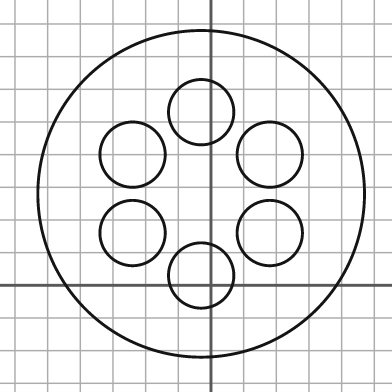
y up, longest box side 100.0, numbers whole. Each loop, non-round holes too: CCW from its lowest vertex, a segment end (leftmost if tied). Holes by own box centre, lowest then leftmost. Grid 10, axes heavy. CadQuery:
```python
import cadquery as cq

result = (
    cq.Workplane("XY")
    .moveTo(-3.0, 28.0)
    .circle(50.0)
    .moveTo(-3.0, 3.0)
    .circle(10.0)
    .moveTo(-24.0, 16.0)
    .circle(10.0)
    .moveTo(18.0, 16.0)
    .circle(10.0)
    .moveTo(-24.0, 40.0)
    .circle(10.0)
    .moveTo(18.0, 40.0)
    .circle(10.0)
    .moveTo(-3.0, 53.0)
    .circle(10.0)
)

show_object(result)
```